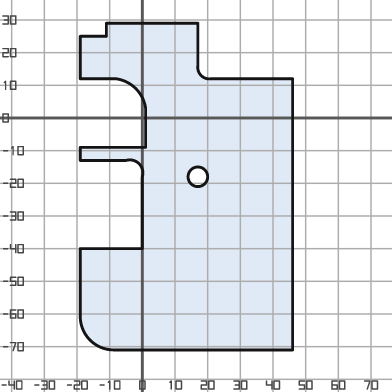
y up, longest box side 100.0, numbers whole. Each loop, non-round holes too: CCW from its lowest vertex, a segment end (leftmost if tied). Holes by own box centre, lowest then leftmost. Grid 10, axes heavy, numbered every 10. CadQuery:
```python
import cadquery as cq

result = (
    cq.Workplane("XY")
    .moveTo(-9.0, -71.0)
    .lineTo(46.0, -71.0)
    .lineTo(46.0, 12.0)
    .lineTo(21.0, 12.0)
    .threePointArc((18.0, 13.0), (17.0, 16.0))
    .lineTo(17.0, 29.0)
    .lineTo(-11.0, 29.0)
    .lineTo(-11.0, 25.0)
    .lineTo(-19.0, 25.0)
    .lineTo(-19.0, 12.0)
    .lineTo(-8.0, 12.0)
    .threePointArc((-2.0, 9.0), (1.0, 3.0))
    .lineTo(1.0, -9.0)
    .lineTo(-19.0, -9.0)
    .lineTo(-19.0, -13.0)
    .lineTo(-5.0, -13.0)
    .threePointArc((-1.0, -14.0), (0.0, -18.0))
    .lineTo(0.0, -40.0)
    .lineTo(-19.0, -40.0)
    .lineTo(-19.0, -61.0)
    .threePointArc((-16.0, -68.0), (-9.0, -71.0))
    .close()
    .moveTo(17.0, -18.0)
    .circle(3.0)
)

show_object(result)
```